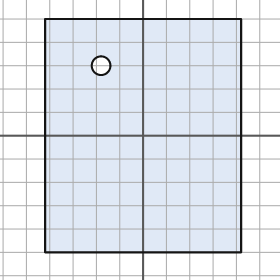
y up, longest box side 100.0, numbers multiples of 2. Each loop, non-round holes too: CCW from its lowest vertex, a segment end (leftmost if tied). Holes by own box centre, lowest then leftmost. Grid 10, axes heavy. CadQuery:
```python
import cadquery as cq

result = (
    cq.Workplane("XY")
    .moveTo(-42.0, -50.0)
    .lineTo(42.0, -50.0)
    .lineTo(42.0, 50.0)
    .lineTo(-42.0, 50.0)
    .close()
    .moveTo(-18.0, 30.0)
    .circle(4.0)
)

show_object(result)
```